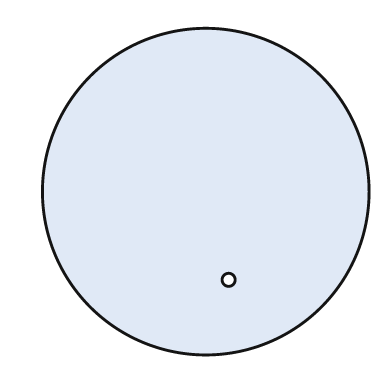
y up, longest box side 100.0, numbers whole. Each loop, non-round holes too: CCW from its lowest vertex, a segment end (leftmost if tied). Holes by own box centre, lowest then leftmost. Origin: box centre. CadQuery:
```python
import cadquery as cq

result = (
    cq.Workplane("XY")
    .moveTo(0.0, 0.0)
    .circle(50.0)
    .moveTo(7.0, -27.0)
    .circle(2.0)
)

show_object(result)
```